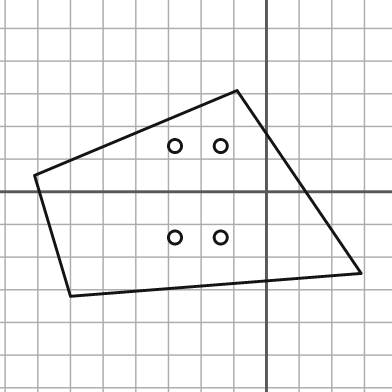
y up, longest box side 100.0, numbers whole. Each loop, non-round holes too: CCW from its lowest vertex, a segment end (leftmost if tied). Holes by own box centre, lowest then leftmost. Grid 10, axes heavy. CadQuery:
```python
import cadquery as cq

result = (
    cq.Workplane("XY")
    .moveTo(-60.0, -32.0)
    .lineTo(29.0, -25.0)
    .lineTo(-9.0, 31.0)
    .lineTo(-71.0, 5.0)
    .close()
    .moveTo(-28.0, -14.0)
    .circle(2.0)
    .moveTo(-14.0, -14.0)
    .circle(2.0)
    .moveTo(-28.0, 14.0)
    .circle(2.0)
    .moveTo(-14.0, 14.0)
    .circle(2.0)
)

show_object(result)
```